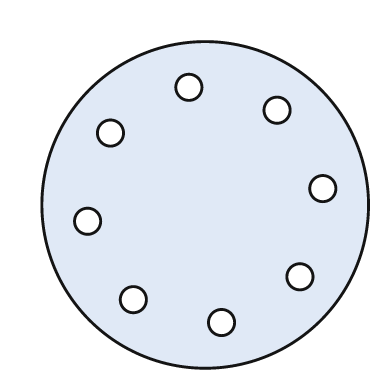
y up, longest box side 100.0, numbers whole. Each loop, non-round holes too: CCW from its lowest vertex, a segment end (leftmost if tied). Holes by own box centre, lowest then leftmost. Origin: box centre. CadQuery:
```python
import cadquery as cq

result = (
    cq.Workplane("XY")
    .moveTo(0.0, 0.0)
    .circle(50.0)
    .moveTo(5.0, -36.0)
    .circle(4.0)
    .moveTo(-22.0, -29.0)
    .circle(4.0)
    .moveTo(29.0, -22.0)
    .circle(4.0)
    .moveTo(-36.0, -5.0)
    .circle(4.0)
    .moveTo(36.0, 5.0)
    .circle(4.0)
    .moveTo(-29.0, 22.0)
    .circle(4.0)
    .moveTo(22.0, 29.0)
    .circle(4.0)
    .moveTo(-5.0, 36.0)
    .circle(4.0)
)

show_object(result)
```